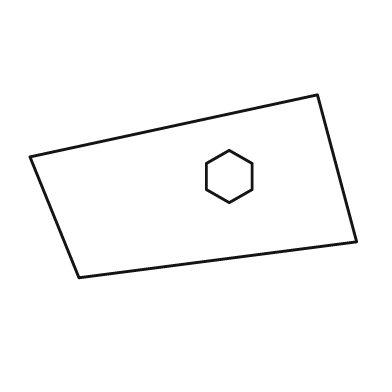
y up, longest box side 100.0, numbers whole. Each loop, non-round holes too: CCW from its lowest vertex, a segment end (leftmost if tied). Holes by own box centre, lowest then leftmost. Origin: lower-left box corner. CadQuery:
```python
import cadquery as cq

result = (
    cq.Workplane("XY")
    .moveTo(15.0, 0.0)
    .lineTo(100.0, 11.0)
    .lineTo(88.0, 56.0)
    .lineTo(0.0, 37.0)
    .close()
    .moveTo(61.0, 23.0)
    .lineTo(68.0, 27.0)
    .lineTo(68.0, 35.0)
    .lineTo(61.0, 39.0)
    .lineTo(54.0, 35.0)
    .lineTo(54.0, 27.0)
    .close()
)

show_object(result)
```